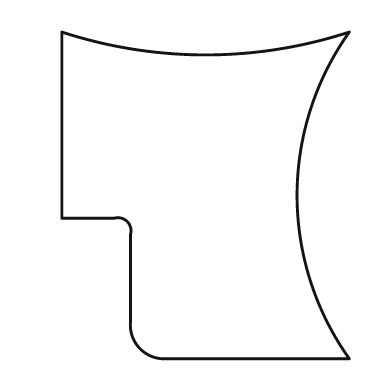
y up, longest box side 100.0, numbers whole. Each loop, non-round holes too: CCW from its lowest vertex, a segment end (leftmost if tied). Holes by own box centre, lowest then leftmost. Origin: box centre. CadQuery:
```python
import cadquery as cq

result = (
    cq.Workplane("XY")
    .moveTo(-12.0, -50.0)
    .lineTo(44.0, -50.0)
    .threePointArc((28.0, 0.0), (44.0, 50.0))
    .threePointArc((0.0, 43.0), (-44.0, 50.0))
    .lineTo(-44.0, -7.0)
    .lineTo(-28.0, -7.0)
    .threePointArc((-24.0, -8.0), (-23.0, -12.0))
    .lineTo(-23.0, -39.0)
    .threePointArc((-20.0, -47.0), (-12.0, -50.0))
    .close()
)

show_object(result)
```